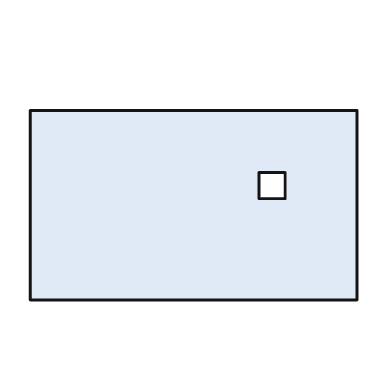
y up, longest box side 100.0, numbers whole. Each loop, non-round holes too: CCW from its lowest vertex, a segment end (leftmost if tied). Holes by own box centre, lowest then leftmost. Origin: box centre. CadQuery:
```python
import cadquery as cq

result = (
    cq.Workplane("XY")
    .moveTo(-50.0, -29.0)
    .lineTo(50.0, -29.0)
    .lineTo(50.0, 29.0)
    .lineTo(-50.0, 29.0)
    .close()
    .moveTo(20.0, 2.0)
    .lineTo(28.0, 2.0)
    .lineTo(28.0, 10.0)
    .lineTo(20.0, 10.0)
    .close()
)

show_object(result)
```